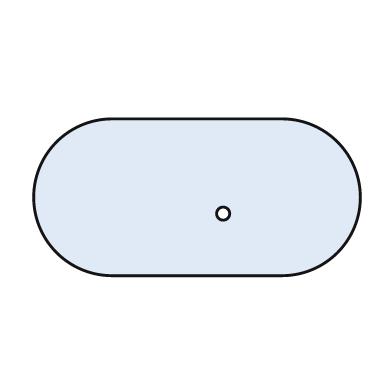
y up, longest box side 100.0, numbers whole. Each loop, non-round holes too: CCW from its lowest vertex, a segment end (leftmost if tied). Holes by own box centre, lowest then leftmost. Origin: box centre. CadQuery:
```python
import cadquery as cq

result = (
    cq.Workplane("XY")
    .moveTo(-26.0, -24.0)
    .lineTo(26.0, -24.0)
    .threePointArc((50.0, 0.0), (26.0, 24.0))
    .lineTo(-26.0, 24.0)
    .threePointArc((-50.0, 0.0), (-26.0, -24.0))
    .close()
    .moveTo(8.0, -5.0)
    .circle(2.0)
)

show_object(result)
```